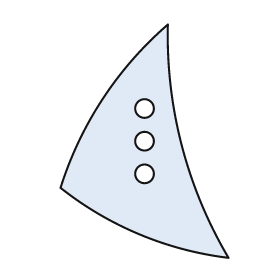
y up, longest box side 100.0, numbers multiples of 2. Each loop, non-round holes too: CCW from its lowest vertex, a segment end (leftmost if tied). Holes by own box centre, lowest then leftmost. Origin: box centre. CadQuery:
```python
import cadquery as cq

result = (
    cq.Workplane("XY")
    .moveTo(36.0, -50.0)
    .threePointArc((16.0, -2.0), (10.0, 50.0))
    .threePointArc((-18.0, 18.0), (-36.0, -20.0))
    .threePointArc((-2.0, -40.0), (36.0, -50.0))
    .close()
    .moveTo(0.0, -14.0)
    .circle(4.0)
    .moveTo(0.0, 0.0)
    .circle(4.0)
    .moveTo(0.0, 14.0)
    .circle(4.0)
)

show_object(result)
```